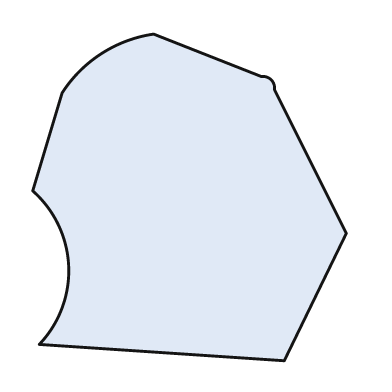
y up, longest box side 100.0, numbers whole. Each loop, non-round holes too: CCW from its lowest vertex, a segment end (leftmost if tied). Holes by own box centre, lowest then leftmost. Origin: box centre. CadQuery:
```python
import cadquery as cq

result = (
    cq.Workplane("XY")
    .moveTo(29.0, -50.0)
    .lineTo(48.0, -11.0)
    .lineTo(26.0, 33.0)
    .threePointArc((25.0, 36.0), (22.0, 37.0))
    .lineTo(-11.0, 50.0)
    .threePointArc((-27.0, 44.0), (-39.0, 32.0))
    .lineTo(-48.0, 2.0)
    .threePointArc((-37.0, -21.0), (-46.0, -45.0))
    .close()
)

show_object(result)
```